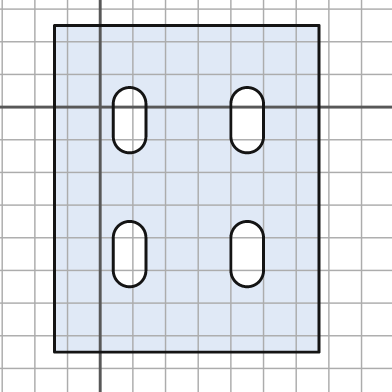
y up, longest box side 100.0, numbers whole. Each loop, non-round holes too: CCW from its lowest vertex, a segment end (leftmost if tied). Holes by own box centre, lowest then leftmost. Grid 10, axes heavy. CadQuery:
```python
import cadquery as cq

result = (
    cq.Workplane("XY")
    .moveTo(-14.0, -75.0)
    .lineTo(67.0, -75.0)
    .lineTo(67.0, 25.0)
    .lineTo(-14.0, 25.0)
    .close()
    .moveTo(4.0, -50.0)
    .threePointArc((9.0, -55.0), (14.0, -50.0))
    .lineTo(14.0, -40.0)
    .threePointArc((9.0, -35.0), (4.0, -40.0))
    .close()
    .moveTo(40.0, -50.0)
    .threePointArc((45.0, -55.0), (50.0, -50.0))
    .lineTo(50.0, -40.0)
    .threePointArc((45.0, -35.0), (40.0, -40.0))
    .close()
    .moveTo(4.0, -9.0)
    .threePointArc((9.0, -14.0), (14.0, -9.0))
    .lineTo(14.0, 1.0)
    .threePointArc((9.0, 6.0), (4.0, 1.0))
    .close()
    .moveTo(40.0, -9.0)
    .threePointArc((45.0, -14.0), (50.0, -9.0))
    .lineTo(50.0, 1.0)
    .threePointArc((45.0, 6.0), (40.0, 1.0))
    .close()
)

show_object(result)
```